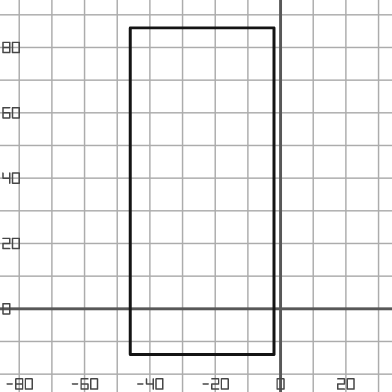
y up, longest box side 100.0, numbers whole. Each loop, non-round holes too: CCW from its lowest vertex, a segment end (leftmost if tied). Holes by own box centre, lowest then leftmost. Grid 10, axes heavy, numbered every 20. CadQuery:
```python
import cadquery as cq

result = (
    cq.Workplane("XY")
    .moveTo(-46.0, -14.0)
    .lineTo(-2.0, -14.0)
    .lineTo(-2.0, 86.0)
    .lineTo(-46.0, 86.0)
    .close()
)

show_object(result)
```